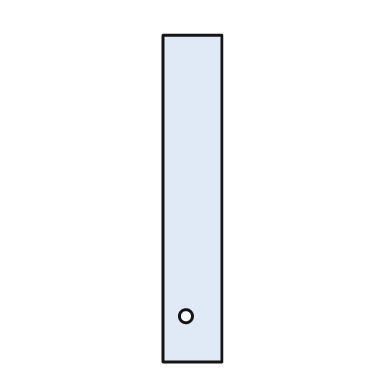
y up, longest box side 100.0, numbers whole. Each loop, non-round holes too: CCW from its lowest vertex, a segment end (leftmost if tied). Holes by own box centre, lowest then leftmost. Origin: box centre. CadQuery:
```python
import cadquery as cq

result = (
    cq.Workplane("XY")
    .moveTo(-9.0, -50.0)
    .lineTo(9.0, -50.0)
    .lineTo(9.0, 50.0)
    .lineTo(-9.0, 50.0)
    .close()
    .moveTo(-2.0, -36.0)
    .circle(2.0)
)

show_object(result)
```